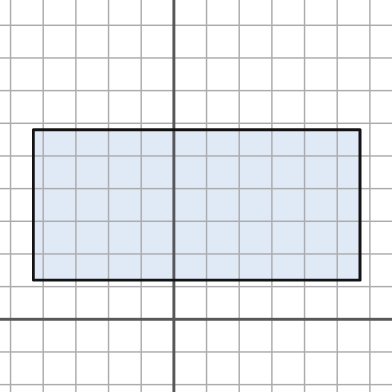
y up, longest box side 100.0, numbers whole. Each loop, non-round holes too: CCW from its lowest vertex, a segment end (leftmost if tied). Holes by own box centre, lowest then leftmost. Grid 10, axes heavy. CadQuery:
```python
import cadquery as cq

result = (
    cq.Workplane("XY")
    .moveTo(-43.0, 12.0)
    .lineTo(57.0, 12.0)
    .lineTo(57.0, 58.0)
    .lineTo(-43.0, 58.0)
    .close()
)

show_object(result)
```